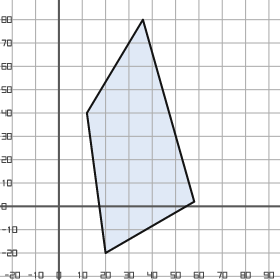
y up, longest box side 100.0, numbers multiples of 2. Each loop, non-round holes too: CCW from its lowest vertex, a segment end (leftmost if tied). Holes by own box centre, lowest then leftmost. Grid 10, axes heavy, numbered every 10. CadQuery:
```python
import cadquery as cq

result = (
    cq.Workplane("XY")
    .moveTo(20.0, -20.0)
    .lineTo(58.0, 2.0)
    .lineTo(36.0, 80.0)
    .lineTo(12.0, 40.0)
    .close()
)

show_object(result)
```